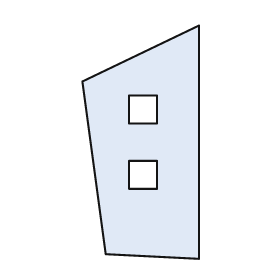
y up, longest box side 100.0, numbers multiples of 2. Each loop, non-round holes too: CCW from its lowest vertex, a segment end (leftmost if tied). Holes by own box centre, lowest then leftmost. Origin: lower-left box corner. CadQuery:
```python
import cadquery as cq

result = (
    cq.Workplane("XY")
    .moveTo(50.0, 0.0)
    .lineTo(50.0, 100.0)
    .lineTo(0.0, 76.0)
    .lineTo(10.0, 2.0)
    .close()
    .moveTo(20.0, 30.0)
    .lineTo(32.0, 30.0)
    .lineTo(32.0, 42.0)
    .lineTo(20.0, 42.0)
    .close()
    .moveTo(20.0, 58.0)
    .lineTo(32.0, 58.0)
    .lineTo(32.0, 70.0)
    .lineTo(20.0, 70.0)
    .close()
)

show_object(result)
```